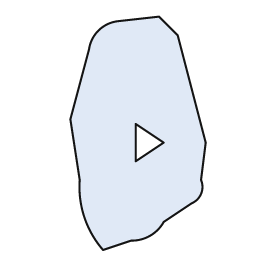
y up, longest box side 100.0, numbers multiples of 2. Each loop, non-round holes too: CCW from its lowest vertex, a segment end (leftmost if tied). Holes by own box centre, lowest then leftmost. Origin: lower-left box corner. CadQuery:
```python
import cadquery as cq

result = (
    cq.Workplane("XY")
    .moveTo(14.0, 0.0)
    .lineTo(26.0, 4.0)
    .threePointArc((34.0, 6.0), (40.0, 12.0))
    .lineTo(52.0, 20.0)
    .threePointArc((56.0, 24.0), (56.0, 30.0))
    .lineTo(58.0, 46.0)
    .lineTo(46.0, 92.0)
    .lineTo(38.0, 100.0)
    .lineTo(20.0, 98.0)
    .threePointArc((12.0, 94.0), (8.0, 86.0))
    .lineTo(0.0, 56.0)
    .lineTo(4.0, 30.0)
    .threePointArc((6.0, 14.0), (14.0, 0.0))
    .close()
    .moveTo(28.0, 38.0)
    .lineTo(40.0, 46.0)
    .lineTo(28.0, 54.0)
    .close()
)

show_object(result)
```